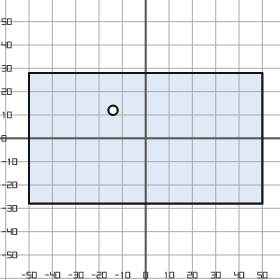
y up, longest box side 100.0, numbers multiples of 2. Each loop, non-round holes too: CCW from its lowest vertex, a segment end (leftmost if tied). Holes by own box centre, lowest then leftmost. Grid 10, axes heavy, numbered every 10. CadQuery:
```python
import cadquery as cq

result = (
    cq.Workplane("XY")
    .moveTo(-50.0, -28.0)
    .lineTo(50.0, -28.0)
    .lineTo(50.0, 28.0)
    .lineTo(-50.0, 28.0)
    .close()
    .moveTo(-14.0, 12.0)
    .circle(2.0)
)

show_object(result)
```